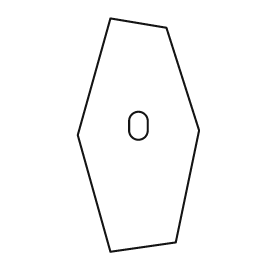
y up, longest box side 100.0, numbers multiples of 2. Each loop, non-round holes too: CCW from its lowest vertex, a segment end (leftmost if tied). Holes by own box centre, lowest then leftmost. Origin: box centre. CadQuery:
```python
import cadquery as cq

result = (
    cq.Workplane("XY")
    .moveTo(-12.0, -50.0)
    .lineTo(16.0, -46.0)
    .lineTo(26.0, 2.0)
    .lineTo(12.0, 46.0)
    .lineTo(-12.0, 50.0)
    .lineTo(-26.0, 0.0)
    .close()
    .moveTo(-4.0, 2.0)
    .threePointArc((0.0, -2.0), (4.0, 2.0))
    .lineTo(4.0, 6.0)
    .threePointArc((0.0, 10.0), (-4.0, 6.0))
    .close()
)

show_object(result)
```